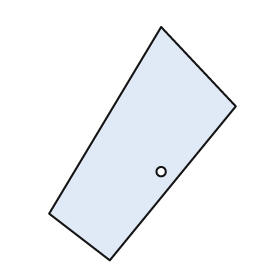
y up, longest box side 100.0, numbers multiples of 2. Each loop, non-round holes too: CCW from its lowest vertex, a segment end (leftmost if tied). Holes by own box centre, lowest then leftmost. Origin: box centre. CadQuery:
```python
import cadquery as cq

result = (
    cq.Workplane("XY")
    .moveTo(-14.0, -50.0)
    .lineTo(40.0, 16.0)
    .lineTo(8.0, 50.0)
    .lineTo(-40.0, -30.0)
    .close()
    .moveTo(8.0, -12.0)
    .circle(2.0)
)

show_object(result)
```